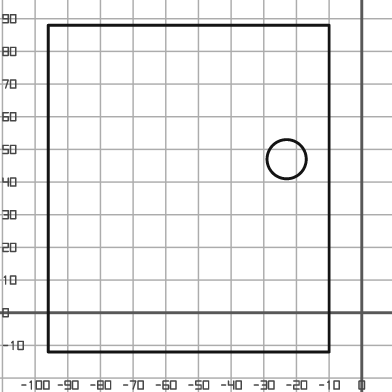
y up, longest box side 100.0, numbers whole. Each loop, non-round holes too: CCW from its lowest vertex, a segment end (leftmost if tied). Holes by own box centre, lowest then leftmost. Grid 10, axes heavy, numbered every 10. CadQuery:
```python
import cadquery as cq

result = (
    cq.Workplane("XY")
    .moveTo(-96.0, -12.0)
    .lineTo(-10.0, -12.0)
    .lineTo(-10.0, 88.0)
    .lineTo(-96.0, 88.0)
    .close()
    .moveTo(-23.0, 47.0)
    .circle(6.0)
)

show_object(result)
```